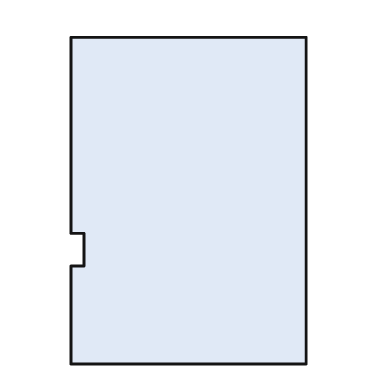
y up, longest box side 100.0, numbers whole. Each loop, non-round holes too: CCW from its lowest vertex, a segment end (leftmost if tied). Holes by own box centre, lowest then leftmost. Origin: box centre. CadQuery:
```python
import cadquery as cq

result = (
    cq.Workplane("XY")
    .moveTo(-36.0, -50.0)
    .lineTo(36.0, -50.0)
    .lineTo(36.0, 50.0)
    .lineTo(-36.0, 50.0)
    .lineTo(-36.0, -10.0)
    .lineTo(-32.0, -10.0)
    .lineTo(-32.0, -20.0)
    .lineTo(-36.0, -20.0)
    .close()
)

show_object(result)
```